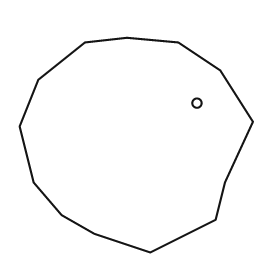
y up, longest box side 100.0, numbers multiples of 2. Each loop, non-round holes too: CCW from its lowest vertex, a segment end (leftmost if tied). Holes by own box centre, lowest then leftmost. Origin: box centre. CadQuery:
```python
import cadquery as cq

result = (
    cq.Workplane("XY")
    .moveTo(6.0, -46.0)
    .lineTo(34.0, -32.0)
    .lineTo(38.0, -16.0)
    .lineTo(50.0, 10.0)
    .lineTo(36.0, 32.0)
    .lineTo(18.0, 44.0)
    .lineTo(-4.0, 46.0)
    .lineTo(-22.0, 44.0)
    .lineTo(-42.0, 28.0)
    .lineTo(-50.0, 8.0)
    .lineTo(-44.0, -16.0)
    .lineTo(-32.0, -30.0)
    .lineTo(-18.0, -38.0)
    .close()
    .moveTo(26.0, 18.0)
    .circle(2.0)
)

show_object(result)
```